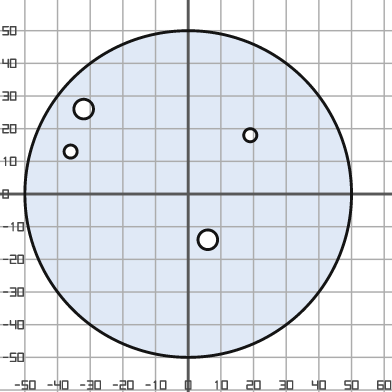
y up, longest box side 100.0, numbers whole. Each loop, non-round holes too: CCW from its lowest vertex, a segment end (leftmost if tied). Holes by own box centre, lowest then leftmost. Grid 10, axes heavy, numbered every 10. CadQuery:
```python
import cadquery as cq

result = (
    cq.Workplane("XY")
    .moveTo(0.0, 0.0)
    .circle(50.0)
    .moveTo(6.0, -14.0)
    .circle(3.0)
    .moveTo(-36.0, 13.0)
    .circle(2.0)
    .moveTo(19.0, 18.0)
    .circle(2.0)
    .moveTo(-32.0, 26.0)
    .circle(3.0)
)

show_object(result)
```